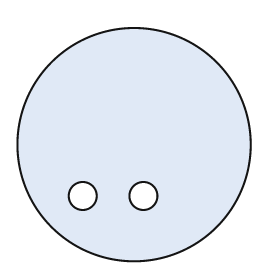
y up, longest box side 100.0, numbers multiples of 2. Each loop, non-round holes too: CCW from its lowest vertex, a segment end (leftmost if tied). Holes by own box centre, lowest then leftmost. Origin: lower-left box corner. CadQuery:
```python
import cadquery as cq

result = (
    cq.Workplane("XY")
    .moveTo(50.0, 50.0)
    .circle(50.0)
    .moveTo(28.0, 28.0)
    .circle(6.0)
    .moveTo(54.0, 28.0)
    .circle(6.0)
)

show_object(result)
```